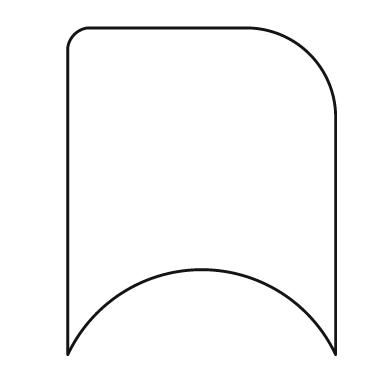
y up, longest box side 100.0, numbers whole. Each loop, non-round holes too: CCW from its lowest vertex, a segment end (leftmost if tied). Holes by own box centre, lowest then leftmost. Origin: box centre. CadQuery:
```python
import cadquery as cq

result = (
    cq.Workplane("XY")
    .moveTo(-41.0, -50.0)
    .threePointArc((0.0, -24.0), (41.0, -50.0))
    .lineTo(41.0, 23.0)
    .threePointArc((33.0, 42.0), (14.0, 50.0))
    .lineTo(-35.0, 50.0)
    .threePointArc((-39.0, 48.0), (-41.0, 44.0))
    .close()
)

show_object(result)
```